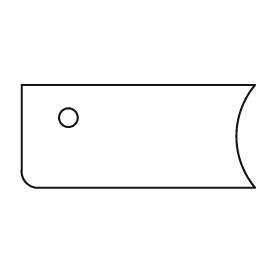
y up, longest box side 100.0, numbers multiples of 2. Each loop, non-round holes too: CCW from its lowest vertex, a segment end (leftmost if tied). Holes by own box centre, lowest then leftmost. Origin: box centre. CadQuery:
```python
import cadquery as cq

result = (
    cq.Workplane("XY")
    .moveTo(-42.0, -22.0)
    .lineTo(50.0, -22.0)
    .threePointArc((42.0, 0.0), (50.0, 22.0))
    .lineTo(-50.0, 22.0)
    .lineTo(-50.0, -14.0)
    .threePointArc((-48.0, -20.0), (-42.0, -22.0))
    .close()
    .moveTo(-30.0, 8.0)
    .circle(4.0)
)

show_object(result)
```